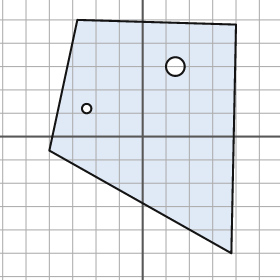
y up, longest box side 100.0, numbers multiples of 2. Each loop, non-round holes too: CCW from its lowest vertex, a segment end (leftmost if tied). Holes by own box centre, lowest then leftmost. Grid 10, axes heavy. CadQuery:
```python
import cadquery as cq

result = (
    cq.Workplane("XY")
    .moveTo(38.0, -50.0)
    .lineTo(40.0, 48.0)
    .lineTo(-28.0, 50.0)
    .lineTo(-40.0, -6.0)
    .close()
    .moveTo(-24.0, 12.0)
    .circle(2.0)
    .moveTo(14.0, 30.0)
    .circle(4.0)
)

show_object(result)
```